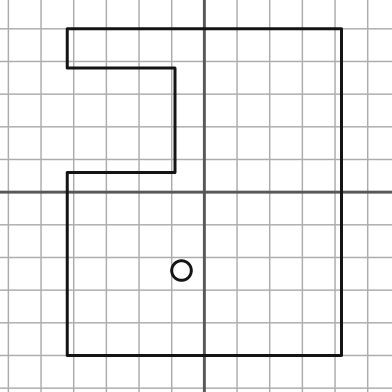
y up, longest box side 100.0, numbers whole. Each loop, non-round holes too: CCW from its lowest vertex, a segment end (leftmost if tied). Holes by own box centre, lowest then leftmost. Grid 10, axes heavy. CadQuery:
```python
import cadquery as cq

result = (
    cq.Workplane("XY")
    .moveTo(-42.0, -50.0)
    .lineTo(42.0, -50.0)
    .lineTo(42.0, 50.0)
    .lineTo(-42.0, 50.0)
    .lineTo(-42.0, 38.0)
    .lineTo(-9.0, 38.0)
    .lineTo(-9.0, 6.0)
    .lineTo(-42.0, 6.0)
    .close()
    .moveTo(-7.0, -24.0)
    .circle(3.0)
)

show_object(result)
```